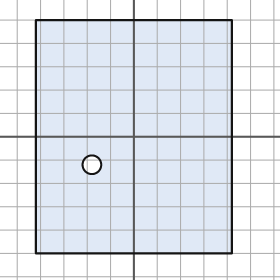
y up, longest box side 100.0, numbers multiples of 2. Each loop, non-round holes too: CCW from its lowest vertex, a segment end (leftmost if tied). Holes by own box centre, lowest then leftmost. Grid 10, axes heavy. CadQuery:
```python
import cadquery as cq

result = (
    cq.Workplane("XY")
    .moveTo(-42.0, -50.0)
    .lineTo(42.0, -50.0)
    .lineTo(42.0, 50.0)
    .lineTo(-42.0, 50.0)
    .close()
    .moveTo(-18.0, -12.0)
    .circle(4.0)
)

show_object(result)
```